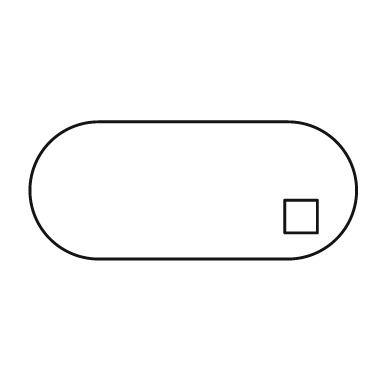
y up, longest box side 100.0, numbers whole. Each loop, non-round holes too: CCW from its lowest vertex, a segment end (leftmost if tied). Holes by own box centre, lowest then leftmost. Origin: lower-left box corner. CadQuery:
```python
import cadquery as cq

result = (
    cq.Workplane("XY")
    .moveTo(21.0, 0.0)
    .lineTo(79.0, 0.0)
    .threePointArc((100.0, 21.0), (79.0, 42.0))
    .lineTo(21.0, 42.0)
    .threePointArc((0.0, 21.0), (21.0, 0.0))
    .close()
    .moveTo(78.0, 8.0)
    .lineTo(88.0, 8.0)
    .lineTo(88.0, 18.0)
    .lineTo(78.0, 18.0)
    .close()
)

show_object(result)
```